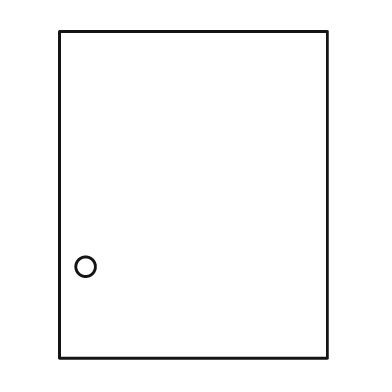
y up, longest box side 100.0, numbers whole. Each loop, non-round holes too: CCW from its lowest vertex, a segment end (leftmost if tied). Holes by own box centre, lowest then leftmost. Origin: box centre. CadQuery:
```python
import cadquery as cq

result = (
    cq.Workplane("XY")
    .moveTo(-41.0, -50.0)
    .lineTo(41.0, -50.0)
    .lineTo(41.0, 50.0)
    .lineTo(-41.0, 50.0)
    .close()
    .moveTo(-33.0, -22.0)
    .circle(3.0)
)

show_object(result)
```